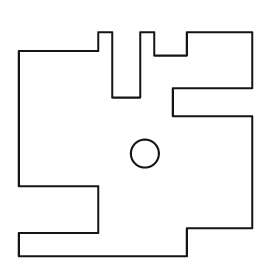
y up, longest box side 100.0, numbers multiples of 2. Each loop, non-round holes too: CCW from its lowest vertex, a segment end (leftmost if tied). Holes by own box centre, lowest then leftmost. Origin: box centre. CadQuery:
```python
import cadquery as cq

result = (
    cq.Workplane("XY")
    .moveTo(-50.0, -48.0)
    .lineTo(22.0, -48.0)
    .lineTo(22.0, -36.0)
    .lineTo(50.0, -36.0)
    .lineTo(50.0, 12.0)
    .lineTo(16.0, 12.0)
    .lineTo(16.0, 24.0)
    .lineTo(50.0, 24.0)
    .lineTo(50.0, 48.0)
    .lineTo(22.0, 48.0)
    .lineTo(22.0, 38.0)
    .lineTo(8.0, 38.0)
    .lineTo(8.0, 48.0)
    .lineTo(2.0, 48.0)
    .lineTo(2.0, 20.0)
    .lineTo(-10.0, 20.0)
    .lineTo(-10.0, 48.0)
    .lineTo(-16.0, 48.0)
    .lineTo(-16.0, 40.0)
    .lineTo(-50.0, 40.0)
    .lineTo(-50.0, -18.0)
    .lineTo(-16.0, -18.0)
    .lineTo(-16.0, -38.0)
    .lineTo(-50.0, -38.0)
    .close()
    .moveTo(4.0, -4.0)
    .circle(6.0)
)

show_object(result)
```